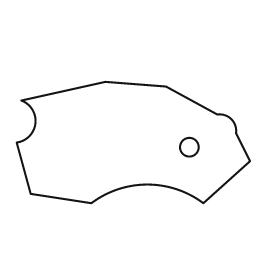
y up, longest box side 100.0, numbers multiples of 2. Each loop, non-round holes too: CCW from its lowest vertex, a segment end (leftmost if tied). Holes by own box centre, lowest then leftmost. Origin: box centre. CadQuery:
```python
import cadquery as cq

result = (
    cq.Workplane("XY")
    .moveTo(-18.0, -26.0)
    .threePointArc((6.0, -18.0), (30.0, -26.0))
    .lineTo(50.0, -8.0)
    .lineTo(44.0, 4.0)
    .threePointArc((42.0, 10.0), (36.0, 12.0))
    .lineTo(14.0, 24.0)
    .lineTo(-12.0, 26.0)
    .lineTo(-48.0, 18.0)
    .threePointArc((-42.0, 8.0), (-50.0, 0.0))
    .lineTo(-44.0, -22.0)
    .close()
    .moveTo(24.0, -2.0)
    .circle(4.0)
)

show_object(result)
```